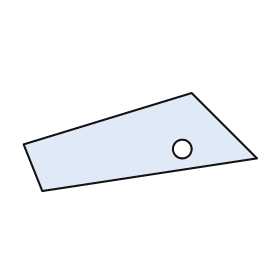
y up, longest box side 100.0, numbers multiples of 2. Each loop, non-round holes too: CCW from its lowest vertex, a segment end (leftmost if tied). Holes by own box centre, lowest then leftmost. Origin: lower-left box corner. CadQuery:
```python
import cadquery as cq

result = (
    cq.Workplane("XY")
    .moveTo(8.0, 0.0)
    .lineTo(100.0, 14.0)
    .lineTo(72.0, 42.0)
    .lineTo(0.0, 20.0)
    .close()
    .moveTo(68.0, 18.0)
    .circle(4.0)
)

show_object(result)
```